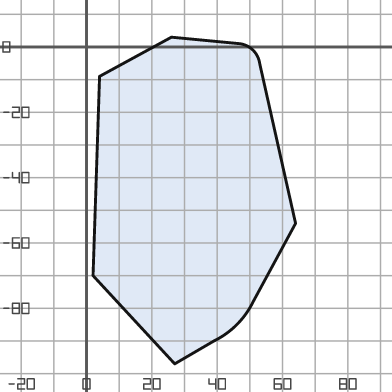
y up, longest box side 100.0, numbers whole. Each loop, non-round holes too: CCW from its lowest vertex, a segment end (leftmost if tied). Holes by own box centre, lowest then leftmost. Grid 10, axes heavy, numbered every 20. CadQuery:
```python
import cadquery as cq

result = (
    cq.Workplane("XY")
    .moveTo(27.0, -97.0)
    .lineTo(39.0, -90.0)
    .threePointArc((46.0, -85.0), (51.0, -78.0))
    .lineTo(64.0, -54.0)
    .lineTo(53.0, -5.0)
    .threePointArc((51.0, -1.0), (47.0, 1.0))
    .lineTo(26.0, 3.0)
    .lineTo(4.0, -9.0)
    .lineTo(2.0, -70.0)
    .close()
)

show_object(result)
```